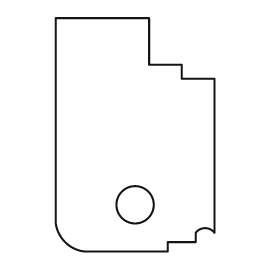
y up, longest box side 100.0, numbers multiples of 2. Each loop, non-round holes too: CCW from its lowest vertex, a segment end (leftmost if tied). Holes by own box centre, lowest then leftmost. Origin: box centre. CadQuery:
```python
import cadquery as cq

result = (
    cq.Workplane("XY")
    .moveTo(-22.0, -50.0)
    .lineTo(14.0, -50.0)
    .lineTo(14.0, -46.0)
    .lineTo(26.0, -46.0)
    .lineTo(26.0, -42.0)
    .threePointArc((30.0, -40.0), (34.0, -42.0))
    .lineTo(34.0, 24.0)
    .lineTo(20.0, 24.0)
    .lineTo(20.0, 30.0)
    .lineTo(6.0, 30.0)
    .lineTo(6.0, 50.0)
    .lineTo(-34.0, 50.0)
    .lineTo(-34.0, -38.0)
    .threePointArc((-30.0, -46.0), (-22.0, -50.0))
    .close()
    .moveTo(0.0, -30.0)
    .circle(8.0)
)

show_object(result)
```